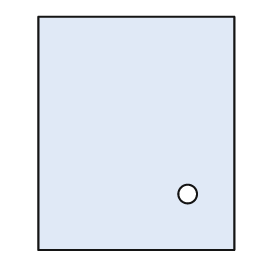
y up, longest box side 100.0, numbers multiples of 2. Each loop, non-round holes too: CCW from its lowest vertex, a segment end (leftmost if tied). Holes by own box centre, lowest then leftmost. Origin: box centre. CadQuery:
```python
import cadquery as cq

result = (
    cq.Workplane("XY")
    .moveTo(-42.0, -50.0)
    .lineTo(42.0, -50.0)
    .lineTo(42.0, 50.0)
    .lineTo(-42.0, 50.0)
    .close()
    .moveTo(22.0, -26.0)
    .circle(4.0)
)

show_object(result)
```